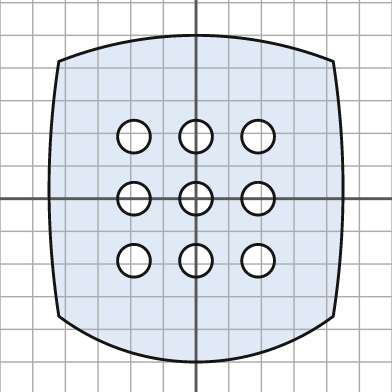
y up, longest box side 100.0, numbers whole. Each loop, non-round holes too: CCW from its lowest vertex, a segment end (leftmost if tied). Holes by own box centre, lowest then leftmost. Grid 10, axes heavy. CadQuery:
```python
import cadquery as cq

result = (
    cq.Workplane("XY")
    .moveTo(-42.0, -36.0)
    .threePointArc((0.0, -50.0), (42.0, -36.0))
    .threePointArc((45.0, 3.0), (42.0, 42.0))
    .threePointArc((0.0, 50.0), (-42.0, 42.0))
    .threePointArc((-45.0, 3.0), (-42.0, -36.0))
    .close()
    .moveTo(-19.0, -19.0)
    .circle(5.0)
    .moveTo(0.0, -19.0)
    .circle(5.0)
    .moveTo(19.0, -19.0)
    .circle(5.0)
    .moveTo(-19.0, 0.0)
    .circle(5.0)
    .moveTo(0.0, 0.0)
    .circle(5.0)
    .moveTo(19.0, 0.0)
    .circle(5.0)
    .moveTo(-19.0, 19.0)
    .circle(5.0)
    .moveTo(0.0, 19.0)
    .circle(5.0)
    .moveTo(19.0, 19.0)
    .circle(5.0)
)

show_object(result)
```